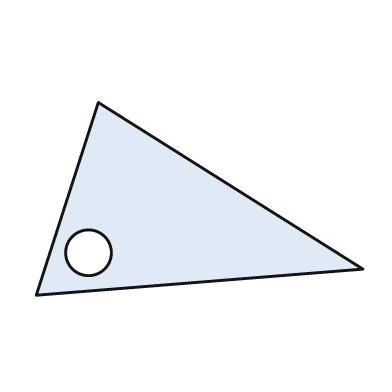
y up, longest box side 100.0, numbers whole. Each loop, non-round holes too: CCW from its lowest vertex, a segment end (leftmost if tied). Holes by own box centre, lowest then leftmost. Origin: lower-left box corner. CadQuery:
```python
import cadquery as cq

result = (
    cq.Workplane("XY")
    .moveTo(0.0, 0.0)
    .lineTo(100.0, 8.0)
    .lineTo(19.0, 59.0)
    .close()
    .moveTo(16.0, 13.0)
    .circle(7.0)
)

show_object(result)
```